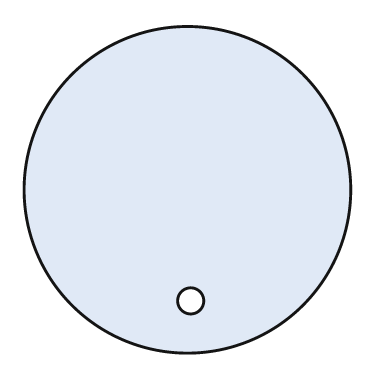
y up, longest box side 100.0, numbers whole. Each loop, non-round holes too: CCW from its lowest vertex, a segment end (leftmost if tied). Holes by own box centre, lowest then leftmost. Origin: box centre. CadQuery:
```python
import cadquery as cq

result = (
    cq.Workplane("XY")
    .moveTo(0.0, 0.0)
    .circle(50.0)
    .moveTo(1.0, -34.0)
    .circle(4.0)
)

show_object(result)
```